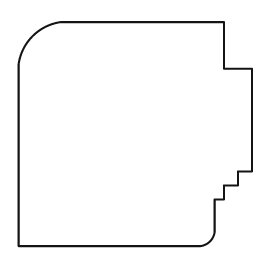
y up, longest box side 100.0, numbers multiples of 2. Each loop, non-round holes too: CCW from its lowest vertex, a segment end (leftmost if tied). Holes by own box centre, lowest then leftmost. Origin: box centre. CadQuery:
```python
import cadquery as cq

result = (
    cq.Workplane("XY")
    .moveTo(-50.0, -48.0)
    .lineTo(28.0, -48.0)
    .threePointArc((32.0, -46.0), (34.0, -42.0))
    .lineTo(34.0, -28.0)
    .lineTo(38.0, -28.0)
    .lineTo(38.0, -22.0)
    .lineTo(44.0, -22.0)
    .lineTo(44.0, -16.0)
    .lineTo(50.0, -16.0)
    .lineTo(50.0, 28.0)
    .lineTo(38.0, 28.0)
    .lineTo(38.0, 48.0)
    .lineTo(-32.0, 48.0)
    .threePointArc((-44.0, 42.0), (-50.0, 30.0))
    .close()
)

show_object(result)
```